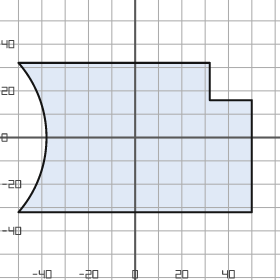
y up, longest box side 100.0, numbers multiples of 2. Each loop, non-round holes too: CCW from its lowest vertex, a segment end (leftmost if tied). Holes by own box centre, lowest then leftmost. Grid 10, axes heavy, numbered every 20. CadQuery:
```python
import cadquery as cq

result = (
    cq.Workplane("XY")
    .moveTo(-50.0, -32.0)
    .lineTo(50.0, -32.0)
    .lineTo(50.0, 16.0)
    .lineTo(32.0, 16.0)
    .lineTo(32.0, 32.0)
    .lineTo(-50.0, 32.0)
    .threePointArc((-38.0, 0.0), (-50.0, -32.0))
    .close()
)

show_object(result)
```